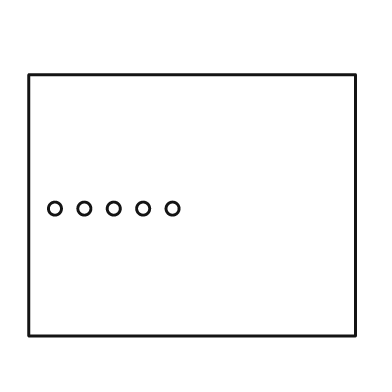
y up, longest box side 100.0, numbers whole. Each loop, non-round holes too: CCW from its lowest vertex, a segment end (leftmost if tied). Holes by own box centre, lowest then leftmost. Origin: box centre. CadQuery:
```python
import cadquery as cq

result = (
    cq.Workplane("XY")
    .moveTo(-50.0, -40.0)
    .lineTo(50.0, -40.0)
    .lineTo(50.0, 40.0)
    .lineTo(-50.0, 40.0)
    .close()
    .moveTo(-42.0, -1.0)
    .circle(2.0)
    .moveTo(-33.0, -1.0)
    .circle(2.0)
    .moveTo(-24.0, -1.0)
    .circle(2.0)
    .moveTo(-15.0, -1.0)
    .circle(2.0)
    .moveTo(-6.0, -1.0)
    .circle(2.0)
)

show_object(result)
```